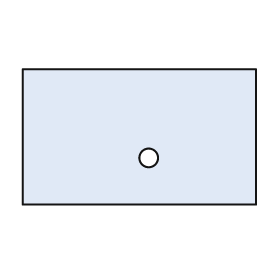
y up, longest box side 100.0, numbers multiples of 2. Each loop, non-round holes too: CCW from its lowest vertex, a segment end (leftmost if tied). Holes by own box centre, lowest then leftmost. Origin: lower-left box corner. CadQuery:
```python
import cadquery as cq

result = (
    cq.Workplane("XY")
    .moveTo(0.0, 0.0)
    .lineTo(100.0, 0.0)
    .lineTo(100.0, 58.0)
    .lineTo(0.0, 58.0)
    .close()
    .moveTo(54.0, 20.0)
    .circle(4.0)
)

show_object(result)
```